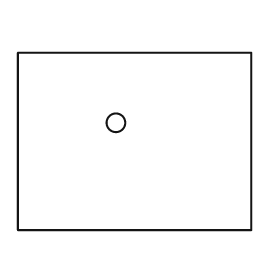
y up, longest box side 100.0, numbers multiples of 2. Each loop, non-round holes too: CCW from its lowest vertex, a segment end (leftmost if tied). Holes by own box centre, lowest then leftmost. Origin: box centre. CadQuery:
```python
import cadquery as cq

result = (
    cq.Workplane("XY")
    .moveTo(-50.0, -38.0)
    .lineTo(50.0, -38.0)
    .lineTo(50.0, 38.0)
    .lineTo(-50.0, 38.0)
    .close()
    .moveTo(-8.0, 8.0)
    .circle(4.0)
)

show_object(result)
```